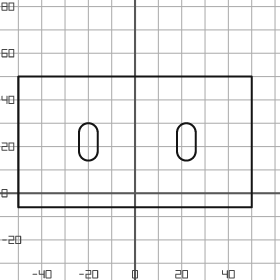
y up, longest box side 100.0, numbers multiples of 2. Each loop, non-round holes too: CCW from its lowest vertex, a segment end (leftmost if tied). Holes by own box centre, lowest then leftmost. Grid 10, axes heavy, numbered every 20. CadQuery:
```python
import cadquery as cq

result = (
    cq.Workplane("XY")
    .moveTo(-50.0, -6.0)
    .lineTo(50.0, -6.0)
    .lineTo(50.0, 50.0)
    .lineTo(-50.0, 50.0)
    .close()
    .moveTo(-24.0, 18.0)
    .threePointArc((-20.0, 14.0), (-16.0, 18.0))
    .lineTo(-16.0, 26.0)
    .threePointArc((-20.0, 30.0), (-24.0, 26.0))
    .close()
    .moveTo(18.0, 18.0)
    .threePointArc((22.0, 14.0), (26.0, 18.0))
    .lineTo(26.0, 26.0)
    .threePointArc((22.0, 30.0), (18.0, 26.0))
    .close()
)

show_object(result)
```